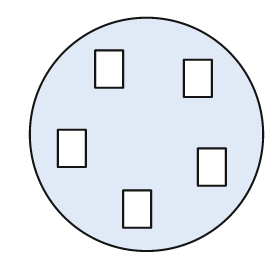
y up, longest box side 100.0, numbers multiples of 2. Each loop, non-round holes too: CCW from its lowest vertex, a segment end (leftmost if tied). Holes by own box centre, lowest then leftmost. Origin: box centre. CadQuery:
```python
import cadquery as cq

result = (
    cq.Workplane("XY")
    .moveTo(0.0, 0.0)
    .circle(50.0)
    .moveTo(-10.0, -40.0)
    .lineTo(2.0, -40.0)
    .lineTo(2.0, -24.0)
    .lineTo(-10.0, -24.0)
    .close()
    .moveTo(22.0, -22.0)
    .lineTo(34.0, -22.0)
    .lineTo(34.0, -6.0)
    .lineTo(22.0, -6.0)
    .close()
    .moveTo(-38.0, -14.0)
    .lineTo(-26.0, -14.0)
    .lineTo(-26.0, 2.0)
    .lineTo(-38.0, 2.0)
    .close()
    .moveTo(16.0, 16.0)
    .lineTo(28.0, 16.0)
    .lineTo(28.0, 32.0)
    .lineTo(16.0, 32.0)
    .close()
    .moveTo(-22.0, 20.0)
    .lineTo(-10.0, 20.0)
    .lineTo(-10.0, 36.0)
    .lineTo(-22.0, 36.0)
    .close()
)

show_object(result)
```